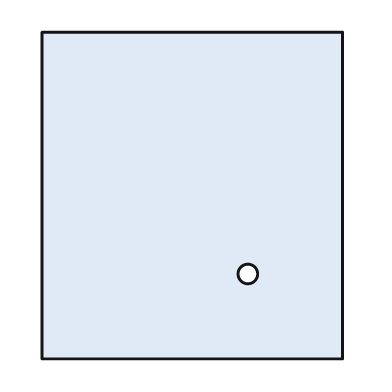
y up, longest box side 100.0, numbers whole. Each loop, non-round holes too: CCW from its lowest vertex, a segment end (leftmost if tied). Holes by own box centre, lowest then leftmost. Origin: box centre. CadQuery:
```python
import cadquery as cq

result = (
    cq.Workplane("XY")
    .moveTo(-46.0, -50.0)
    .lineTo(46.0, -50.0)
    .lineTo(46.0, 50.0)
    .lineTo(-46.0, 50.0)
    .close()
    .moveTo(17.0, -24.0)
    .circle(3.0)
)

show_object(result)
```